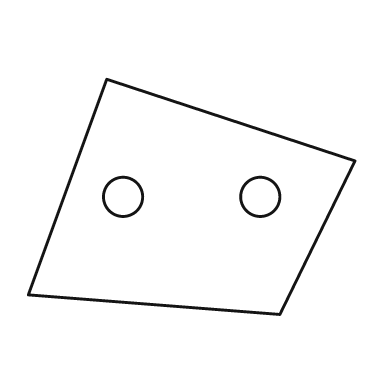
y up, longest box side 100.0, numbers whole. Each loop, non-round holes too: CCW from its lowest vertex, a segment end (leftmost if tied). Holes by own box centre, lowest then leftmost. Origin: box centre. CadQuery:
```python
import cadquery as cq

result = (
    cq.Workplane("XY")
    .moveTo(27.0, -36.0)
    .lineTo(50.0, 11.0)
    .lineTo(-26.0, 36.0)
    .lineTo(-50.0, -30.0)
    .close()
    .moveTo(-21.0, 0.0)
    .circle(6.0)
    .moveTo(21.0, 0.0)
    .circle(6.0)
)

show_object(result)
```